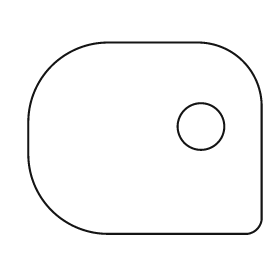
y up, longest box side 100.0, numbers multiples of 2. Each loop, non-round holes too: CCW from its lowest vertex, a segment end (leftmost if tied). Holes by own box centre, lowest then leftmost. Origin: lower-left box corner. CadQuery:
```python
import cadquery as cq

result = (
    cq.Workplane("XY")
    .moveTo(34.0, 0.0)
    .lineTo(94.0, 0.0)
    .threePointArc((98.0, 2.0), (100.0, 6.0))
    .lineTo(100.0, 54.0)
    .threePointArc((92.0, 74.0), (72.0, 82.0))
    .lineTo(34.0, 82.0)
    .threePointArc((10.0, 72.0), (0.0, 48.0))
    .lineTo(0.0, 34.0)
    .threePointArc((10.0, 10.0), (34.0, 0.0))
    .close()
    .moveTo(74.0, 46.0)
    .circle(10.0)
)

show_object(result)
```